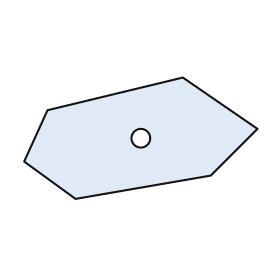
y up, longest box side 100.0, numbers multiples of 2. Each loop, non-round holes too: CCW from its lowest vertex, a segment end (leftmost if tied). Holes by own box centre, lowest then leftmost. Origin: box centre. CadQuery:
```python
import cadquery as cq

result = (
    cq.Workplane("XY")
    .moveTo(-28.0, -26.0)
    .lineTo(30.0, -16.0)
    .lineTo(50.0, 4.0)
    .lineTo(18.0, 26.0)
    .lineTo(-40.0, 12.0)
    .lineTo(-50.0, -10.0)
    .close()
    .moveTo(0.0, 0.0)
    .circle(4.0)
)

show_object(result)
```